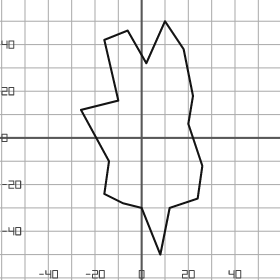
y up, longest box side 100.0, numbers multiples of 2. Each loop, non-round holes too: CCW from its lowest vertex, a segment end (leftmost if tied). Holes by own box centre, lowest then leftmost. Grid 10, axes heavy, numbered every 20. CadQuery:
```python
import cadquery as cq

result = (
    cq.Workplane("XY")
    .moveTo(8.0, -50.0)
    .lineTo(12.0, -30.0)
    .lineTo(24.0, -26.0)
    .lineTo(26.0, -12.0)
    .lineTo(20.0, 6.0)
    .lineTo(22.0, 18.0)
    .lineTo(18.0, 38.0)
    .lineTo(10.0, 50.0)
    .lineTo(2.0, 32.0)
    .lineTo(-6.0, 46.0)
    .lineTo(-16.0, 42.0)
    .lineTo(-10.0, 16.0)
    .lineTo(-26.0, 12.0)
    .lineTo(-14.0, -10.0)
    .lineTo(-16.0, -24.0)
    .lineTo(-8.0, -28.0)
    .lineTo(0.0, -30.0)
    .close()
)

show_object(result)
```